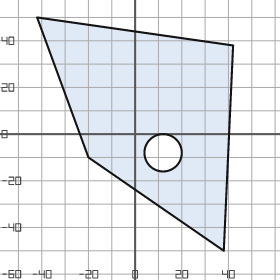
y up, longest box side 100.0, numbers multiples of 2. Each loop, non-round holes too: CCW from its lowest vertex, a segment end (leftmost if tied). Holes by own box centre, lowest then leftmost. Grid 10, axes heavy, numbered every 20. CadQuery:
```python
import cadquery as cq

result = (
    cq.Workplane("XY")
    .moveTo(38.0, -50.0)
    .lineTo(42.0, 38.0)
    .lineTo(-42.0, 50.0)
    .lineTo(-20.0, -10.0)
    .close()
    .moveTo(12.0, -8.0)
    .circle(8.0)
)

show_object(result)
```